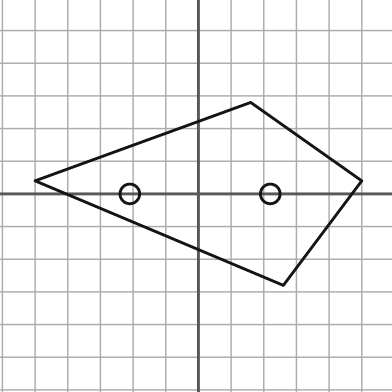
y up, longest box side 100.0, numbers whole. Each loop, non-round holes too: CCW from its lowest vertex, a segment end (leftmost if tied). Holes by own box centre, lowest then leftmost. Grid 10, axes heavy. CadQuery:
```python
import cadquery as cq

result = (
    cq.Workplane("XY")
    .moveTo(26.0, -28.0)
    .lineTo(50.0, 4.0)
    .lineTo(16.0, 28.0)
    .lineTo(-50.0, 4.0)
    .close()
    .moveTo(-21.0, 0.0)
    .circle(3.0)
    .moveTo(22.0, 0.0)
    .circle(3.0)
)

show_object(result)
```